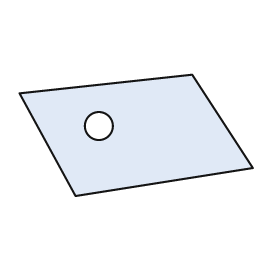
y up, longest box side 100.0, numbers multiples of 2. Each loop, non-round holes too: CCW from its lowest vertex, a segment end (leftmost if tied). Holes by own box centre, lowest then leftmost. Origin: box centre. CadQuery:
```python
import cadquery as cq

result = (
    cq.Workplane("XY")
    .moveTo(-26.0, -26.0)
    .lineTo(50.0, -14.0)
    .lineTo(24.0, 26.0)
    .lineTo(-50.0, 18.0)
    .close()
    .moveTo(-16.0, 4.0)
    .circle(6.0)
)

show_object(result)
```